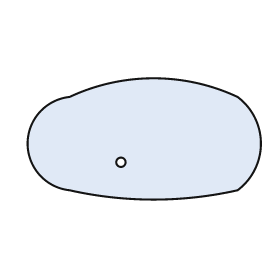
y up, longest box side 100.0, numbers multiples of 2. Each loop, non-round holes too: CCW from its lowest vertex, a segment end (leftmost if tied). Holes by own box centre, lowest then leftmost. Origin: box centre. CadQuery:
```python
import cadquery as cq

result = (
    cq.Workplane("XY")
    .moveTo(-32.0, -22.0)
    .threePointArc((4.0, -26.0), (40.0, -22.0))
    .threePointArc((50.0, -2.0), (40.0, 18.0))
    .threePointArc((4.0, 26.0), (-32.0, 18.0))
    .threePointArc((-50.0, -2.0), (-32.0, -22.0))
    .close()
    .moveTo(-10.0, -10.0)
    .circle(2.0)
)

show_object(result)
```